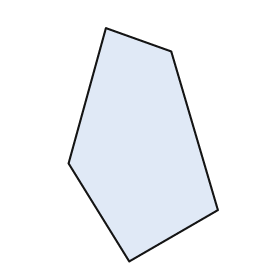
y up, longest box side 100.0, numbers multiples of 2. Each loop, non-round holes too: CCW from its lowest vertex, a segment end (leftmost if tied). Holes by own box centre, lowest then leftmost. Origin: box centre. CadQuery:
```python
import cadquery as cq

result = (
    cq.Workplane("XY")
    .moveTo(-6.0, -50.0)
    .lineTo(32.0, -28.0)
    .lineTo(12.0, 40.0)
    .lineTo(-16.0, 50.0)
    .lineTo(-32.0, -8.0)
    .close()
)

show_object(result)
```